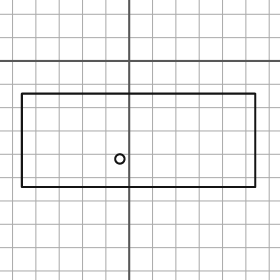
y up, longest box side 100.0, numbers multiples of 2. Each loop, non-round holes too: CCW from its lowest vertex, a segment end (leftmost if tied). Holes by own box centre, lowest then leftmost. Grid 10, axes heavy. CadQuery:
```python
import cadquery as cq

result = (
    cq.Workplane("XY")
    .moveTo(-46.0, -54.0)
    .lineTo(54.0, -54.0)
    .lineTo(54.0, -14.0)
    .lineTo(-46.0, -14.0)
    .close()
    .moveTo(-4.0, -42.0)
    .circle(2.0)
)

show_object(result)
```